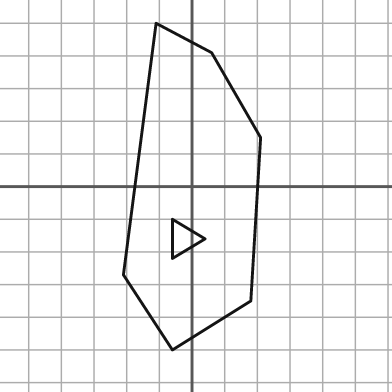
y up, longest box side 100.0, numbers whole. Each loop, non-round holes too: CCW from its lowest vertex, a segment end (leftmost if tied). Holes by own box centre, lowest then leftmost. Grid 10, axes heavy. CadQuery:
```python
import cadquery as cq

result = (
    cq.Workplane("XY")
    .moveTo(-6.0, -50.0)
    .lineTo(18.0, -35.0)
    .lineTo(21.0, 15.0)
    .lineTo(6.0, 41.0)
    .lineTo(-11.0, 50.0)
    .lineTo(-21.0, -27.0)
    .close()
    .moveTo(-6.0, -22.0)
    .lineTo(4.0, -16.0)
    .lineTo(-6.0, -10.0)
    .close()
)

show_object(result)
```